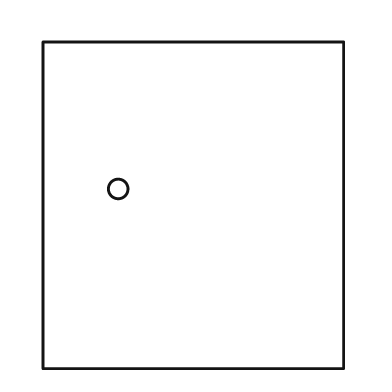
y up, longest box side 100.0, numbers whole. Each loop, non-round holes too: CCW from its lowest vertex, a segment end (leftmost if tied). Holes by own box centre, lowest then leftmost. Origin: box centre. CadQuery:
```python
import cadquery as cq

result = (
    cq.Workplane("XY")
    .moveTo(-46.0, -50.0)
    .lineTo(46.0, -50.0)
    .lineTo(46.0, 50.0)
    .lineTo(-46.0, 50.0)
    .close()
    .moveTo(-23.0, 5.0)
    .circle(3.0)
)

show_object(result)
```